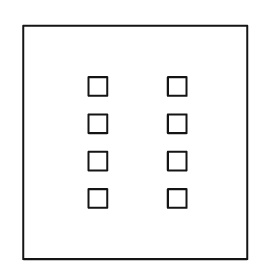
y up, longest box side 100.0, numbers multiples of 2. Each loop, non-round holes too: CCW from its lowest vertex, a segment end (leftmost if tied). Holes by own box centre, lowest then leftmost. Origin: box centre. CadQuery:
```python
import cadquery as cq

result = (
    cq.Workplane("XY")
    .moveTo(-48.0, -50.0)
    .lineTo(48.0, -50.0)
    .lineTo(48.0, 50.0)
    .lineTo(-48.0, 50.0)
    .close()
    .moveTo(-20.0, -28.0)
    .lineTo(-12.0, -28.0)
    .lineTo(-12.0, -20.0)
    .lineTo(-20.0, -20.0)
    .close()
    .moveTo(14.0, -28.0)
    .lineTo(22.0, -28.0)
    .lineTo(22.0, -20.0)
    .lineTo(14.0, -20.0)
    .close()
    .moveTo(-20.0, -12.0)
    .lineTo(-12.0, -12.0)
    .lineTo(-12.0, -4.0)
    .lineTo(-20.0, -4.0)
    .close()
    .moveTo(14.0, -12.0)
    .lineTo(22.0, -12.0)
    .lineTo(22.0, -4.0)
    .lineTo(14.0, -4.0)
    .close()
    .moveTo(-20.0, 4.0)
    .lineTo(-12.0, 4.0)
    .lineTo(-12.0, 12.0)
    .lineTo(-20.0, 12.0)
    .close()
    .moveTo(14.0, 4.0)
    .lineTo(22.0, 4.0)
    .lineTo(22.0, 12.0)
    .lineTo(14.0, 12.0)
    .close()
    .moveTo(-20.0, 20.0)
    .lineTo(-12.0, 20.0)
    .lineTo(-12.0, 28.0)
    .lineTo(-20.0, 28.0)
    .close()
    .moveTo(14.0, 20.0)
    .lineTo(22.0, 20.0)
    .lineTo(22.0, 28.0)
    .lineTo(14.0, 28.0)
    .close()
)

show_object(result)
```